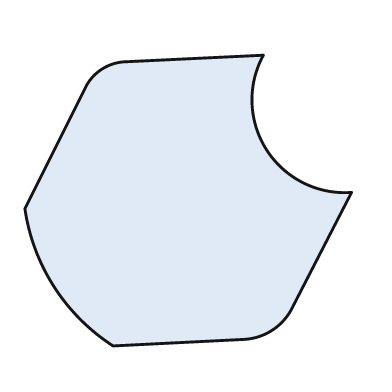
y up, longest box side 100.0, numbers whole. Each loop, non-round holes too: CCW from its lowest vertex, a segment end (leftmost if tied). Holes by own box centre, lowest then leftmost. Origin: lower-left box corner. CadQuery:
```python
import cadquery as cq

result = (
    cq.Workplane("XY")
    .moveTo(27.0, 0.0)
    .lineTo(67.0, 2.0)
    .threePointArc((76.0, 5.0), (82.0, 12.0))
    .lineTo(100.0, 47.0)
    .threePointArc((74.0, 60.0), (73.0, 89.0))
    .lineTo(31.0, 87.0)
    .threePointArc((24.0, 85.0), (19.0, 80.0))
    .lineTo(0.0, 42.0)
    .threePointArc((9.0, 18.0), (27.0, 0.0))
    .close()
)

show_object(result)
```